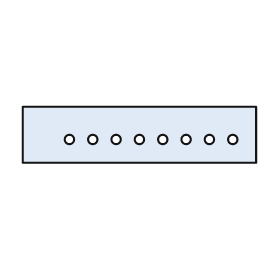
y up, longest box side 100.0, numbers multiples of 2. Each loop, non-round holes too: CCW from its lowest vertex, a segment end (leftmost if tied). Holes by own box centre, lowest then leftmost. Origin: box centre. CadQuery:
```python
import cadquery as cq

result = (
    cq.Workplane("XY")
    .moveTo(-50.0, -12.0)
    .lineTo(50.0, -12.0)
    .lineTo(50.0, 12.0)
    .lineTo(-50.0, 12.0)
    .close()
    .moveTo(-30.0, -2.0)
    .circle(2.0)
    .moveTo(-20.0, -2.0)
    .circle(2.0)
    .moveTo(-10.0, -2.0)
    .circle(2.0)
    .moveTo(0.0, -2.0)
    .circle(2.0)
    .moveTo(10.0, -2.0)
    .circle(2.0)
    .moveTo(20.0, -2.0)
    .circle(2.0)
    .moveTo(30.0, -2.0)
    .circle(2.0)
    .moveTo(40.0, -2.0)
    .circle(2.0)
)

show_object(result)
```